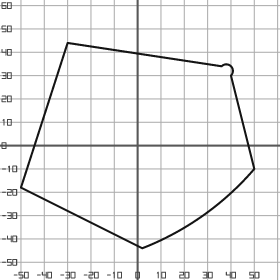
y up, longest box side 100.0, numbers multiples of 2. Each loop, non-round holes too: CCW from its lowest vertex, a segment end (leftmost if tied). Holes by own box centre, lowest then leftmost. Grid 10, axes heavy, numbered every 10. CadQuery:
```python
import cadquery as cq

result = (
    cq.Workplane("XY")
    .moveTo(2.0, -44.0)
    .threePointArc((28.0, -30.0), (50.0, -10.0))
    .lineTo(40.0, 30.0)
    .threePointArc((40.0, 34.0), (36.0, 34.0))
    .lineTo(-30.0, 44.0)
    .lineTo(-50.0, -18.0)
    .close()
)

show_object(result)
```